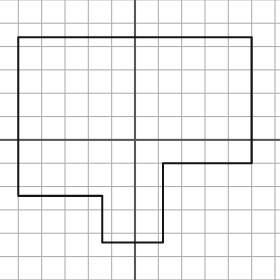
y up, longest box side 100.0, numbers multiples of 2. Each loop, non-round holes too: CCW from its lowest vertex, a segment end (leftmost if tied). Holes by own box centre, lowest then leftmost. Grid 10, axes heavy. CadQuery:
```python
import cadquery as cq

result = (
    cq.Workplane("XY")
    .moveTo(-14.0, -44.0)
    .lineTo(12.0, -44.0)
    .lineTo(12.0, -10.0)
    .lineTo(50.0, -10.0)
    .lineTo(50.0, 44.0)
    .lineTo(-50.0, 44.0)
    .lineTo(-50.0, -24.0)
    .lineTo(-14.0, -24.0)
    .close()
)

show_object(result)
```